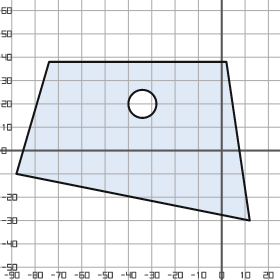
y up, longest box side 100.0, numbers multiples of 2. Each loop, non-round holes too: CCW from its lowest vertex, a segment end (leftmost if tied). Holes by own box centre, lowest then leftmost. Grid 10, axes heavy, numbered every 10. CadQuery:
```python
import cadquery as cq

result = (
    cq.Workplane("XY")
    .moveTo(12.0, -30.0)
    .lineTo(2.0, 38.0)
    .lineTo(-74.0, 38.0)
    .lineTo(-88.0, -10.0)
    .close()
    .moveTo(-34.0, 20.0)
    .circle(6.0)
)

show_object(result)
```